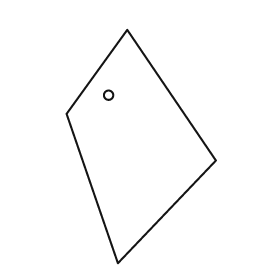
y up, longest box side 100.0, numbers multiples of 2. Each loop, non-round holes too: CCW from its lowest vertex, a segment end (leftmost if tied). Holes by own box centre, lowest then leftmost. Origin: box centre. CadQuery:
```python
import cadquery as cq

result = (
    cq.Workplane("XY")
    .moveTo(-10.0, -50.0)
    .lineTo(32.0, -6.0)
    .lineTo(-6.0, 50.0)
    .lineTo(-32.0, 14.0)
    .close()
    .moveTo(-14.0, 22.0)
    .circle(2.0)
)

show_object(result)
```